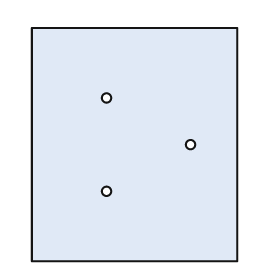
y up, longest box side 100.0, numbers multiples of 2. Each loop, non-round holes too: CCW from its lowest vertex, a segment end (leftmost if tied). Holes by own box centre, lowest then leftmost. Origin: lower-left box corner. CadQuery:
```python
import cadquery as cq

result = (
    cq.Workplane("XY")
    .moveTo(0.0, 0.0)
    .lineTo(88.0, 0.0)
    .lineTo(88.0, 100.0)
    .lineTo(0.0, 100.0)
    .close()
    .moveTo(32.0, 30.0)
    .circle(2.0)
    .moveTo(68.0, 50.0)
    .circle(2.0)
    .moveTo(32.0, 70.0)
    .circle(2.0)
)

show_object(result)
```